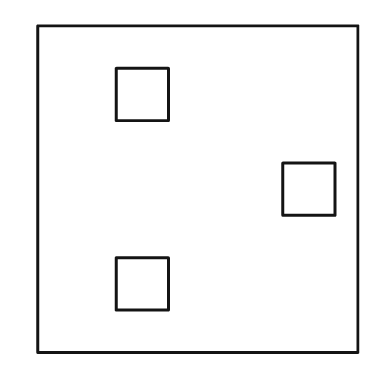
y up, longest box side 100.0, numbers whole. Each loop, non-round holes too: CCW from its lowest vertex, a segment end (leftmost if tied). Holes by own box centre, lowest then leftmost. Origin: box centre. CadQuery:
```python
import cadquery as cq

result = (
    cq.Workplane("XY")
    .moveTo(-49.0, -50.0)
    .lineTo(49.0, -50.0)
    .lineTo(49.0, 50.0)
    .lineTo(-49.0, 50.0)
    .close()
    .moveTo(-25.0, -37.0)
    .lineTo(-9.0, -37.0)
    .lineTo(-9.0, -21.0)
    .lineTo(-25.0, -21.0)
    .close()
    .moveTo(26.0, -8.0)
    .lineTo(42.0, -8.0)
    .lineTo(42.0, 8.0)
    .lineTo(26.0, 8.0)
    .close()
    .moveTo(-25.0, 21.0)
    .lineTo(-9.0, 21.0)
    .lineTo(-9.0, 37.0)
    .lineTo(-25.0, 37.0)
    .close()
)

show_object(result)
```